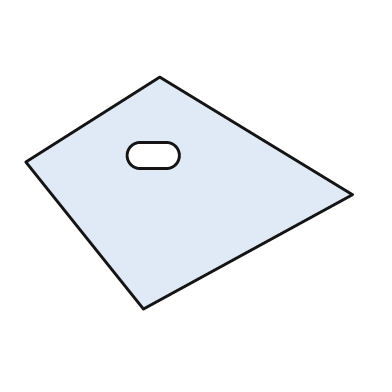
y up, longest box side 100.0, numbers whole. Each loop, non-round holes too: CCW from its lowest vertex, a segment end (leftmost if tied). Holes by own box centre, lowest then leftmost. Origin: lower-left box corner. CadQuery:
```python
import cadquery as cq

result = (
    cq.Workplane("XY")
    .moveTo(36.0, 0.0)
    .lineTo(100.0, 35.0)
    .lineTo(41.0, 71.0)
    .lineTo(0.0, 45.0)
    .close()
    .moveTo(35.0, 43.0)
    .lineTo(43.0, 43.0)
    .threePointArc((47.0, 47.0), (43.0, 51.0))
    .lineTo(35.0, 51.0)
    .threePointArc((31.0, 47.0), (35.0, 43.0))
    .close()
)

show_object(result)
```